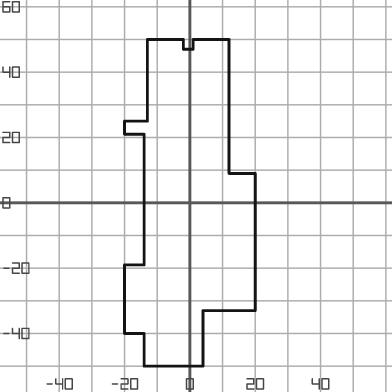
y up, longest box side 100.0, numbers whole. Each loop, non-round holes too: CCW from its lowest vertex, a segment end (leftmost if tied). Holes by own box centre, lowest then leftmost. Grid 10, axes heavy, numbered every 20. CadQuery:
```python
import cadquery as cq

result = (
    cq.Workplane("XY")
    .moveTo(-14.0, -50.0)
    .lineTo(4.0, -50.0)
    .lineTo(4.0, -33.0)
    .lineTo(20.0, -33.0)
    .lineTo(20.0, 9.0)
    .lineTo(12.0, 9.0)
    .lineTo(12.0, 50.0)
    .lineTo(1.0, 50.0)
    .lineTo(1.0, 47.0)
    .lineTo(-2.0, 47.0)
    .lineTo(-2.0, 50.0)
    .lineTo(-13.0, 50.0)
    .lineTo(-13.0, 25.0)
    .lineTo(-20.0, 25.0)
    .lineTo(-20.0, 21.0)
    .lineTo(-14.0, 21.0)
    .lineTo(-14.0, -19.0)
    .lineTo(-20.0, -19.0)
    .lineTo(-20.0, -40.0)
    .lineTo(-14.0, -40.0)
    .close()
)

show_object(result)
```